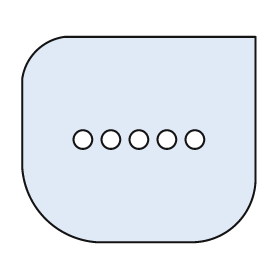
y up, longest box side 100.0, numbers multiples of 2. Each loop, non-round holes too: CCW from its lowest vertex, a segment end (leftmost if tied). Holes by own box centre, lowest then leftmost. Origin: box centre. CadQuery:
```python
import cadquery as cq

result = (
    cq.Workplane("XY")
    .moveTo(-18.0, -44.0)
    .lineTo(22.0, -44.0)
    .threePointArc((42.0, -36.0), (50.0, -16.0))
    .lineTo(50.0, 44.0)
    .lineTo(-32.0, 44.0)
    .threePointArc((-44.0, 38.0), (-50.0, 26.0))
    .lineTo(-50.0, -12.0)
    .threePointArc((-40.0, -34.0), (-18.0, -44.0))
    .close()
    .moveTo(-24.0, 0.0)
    .circle(4.0)
    .moveTo(-12.0, 0.0)
    .circle(4.0)
    .moveTo(0.0, 0.0)
    .circle(4.0)
    .moveTo(12.0, 0.0)
    .circle(4.0)
    .moveTo(24.0, 0.0)
    .circle(4.0)
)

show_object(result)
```